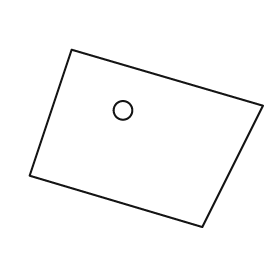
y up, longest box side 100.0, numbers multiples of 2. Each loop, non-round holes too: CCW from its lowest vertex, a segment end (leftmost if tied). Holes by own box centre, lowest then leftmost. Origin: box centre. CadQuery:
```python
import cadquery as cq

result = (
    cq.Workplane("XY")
    .moveTo(24.0, -38.0)
    .lineTo(50.0, 14.0)
    .lineTo(-32.0, 38.0)
    .lineTo(-50.0, -16.0)
    .close()
    .moveTo(-10.0, 12.0)
    .circle(4.0)
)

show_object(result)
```